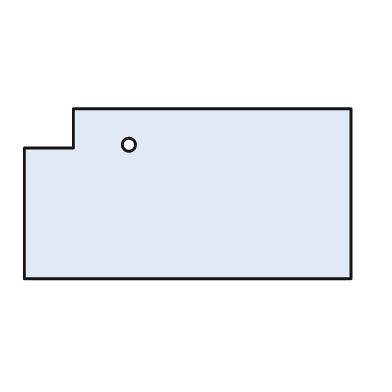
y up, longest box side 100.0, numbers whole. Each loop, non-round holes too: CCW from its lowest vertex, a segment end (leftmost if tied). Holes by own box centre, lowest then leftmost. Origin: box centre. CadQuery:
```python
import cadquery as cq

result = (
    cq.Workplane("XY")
    .moveTo(-50.0, -26.0)
    .lineTo(50.0, -26.0)
    .lineTo(50.0, 26.0)
    .lineTo(-35.0, 26.0)
    .lineTo(-35.0, 14.0)
    .lineTo(-50.0, 14.0)
    .close()
    .moveTo(-18.0, 15.0)
    .circle(2.0)
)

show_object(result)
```